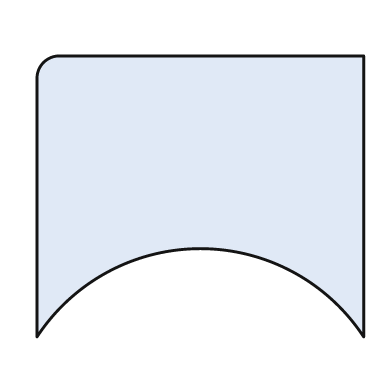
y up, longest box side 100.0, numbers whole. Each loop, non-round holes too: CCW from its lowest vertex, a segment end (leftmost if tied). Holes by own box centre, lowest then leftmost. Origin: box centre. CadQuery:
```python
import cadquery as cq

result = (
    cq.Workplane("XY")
    .moveTo(-50.0, -43.0)
    .threePointArc((0.0, -16.0), (50.0, -43.0))
    .lineTo(50.0, 43.0)
    .lineTo(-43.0, 43.0)
    .threePointArc((-48.0, 41.0), (-50.0, 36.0))
    .close()
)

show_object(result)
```